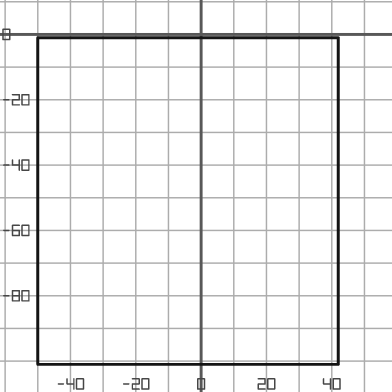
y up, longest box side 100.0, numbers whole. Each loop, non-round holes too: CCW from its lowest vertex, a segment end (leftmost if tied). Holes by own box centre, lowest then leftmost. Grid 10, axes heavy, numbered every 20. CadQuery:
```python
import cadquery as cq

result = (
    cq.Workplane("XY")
    .moveTo(-50.0, -101.0)
    .lineTo(42.0, -101.0)
    .lineTo(42.0, -1.0)
    .lineTo(-50.0, -1.0)
    .close()
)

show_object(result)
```